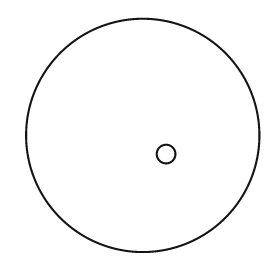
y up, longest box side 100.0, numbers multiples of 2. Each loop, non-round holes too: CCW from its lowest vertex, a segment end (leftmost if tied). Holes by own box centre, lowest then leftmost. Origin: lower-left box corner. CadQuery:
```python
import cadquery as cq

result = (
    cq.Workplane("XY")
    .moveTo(50.0, 50.0)
    .circle(50.0)
    .moveTo(60.0, 42.0)
    .circle(4.0)
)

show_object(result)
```